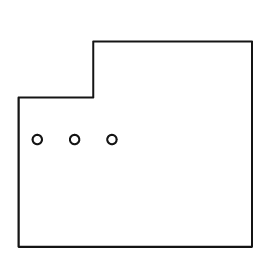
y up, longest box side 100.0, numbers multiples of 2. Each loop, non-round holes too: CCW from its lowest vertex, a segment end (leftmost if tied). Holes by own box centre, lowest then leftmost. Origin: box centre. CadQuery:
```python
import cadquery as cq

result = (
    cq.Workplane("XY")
    .moveTo(-50.0, -44.0)
    .lineTo(50.0, -44.0)
    .lineTo(50.0, 44.0)
    .lineTo(-18.0, 44.0)
    .lineTo(-18.0, 20.0)
    .lineTo(-50.0, 20.0)
    .close()
    .moveTo(-42.0, 2.0)
    .circle(2.0)
    .moveTo(-26.0, 2.0)
    .circle(2.0)
    .moveTo(-10.0, 2.0)
    .circle(2.0)
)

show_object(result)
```